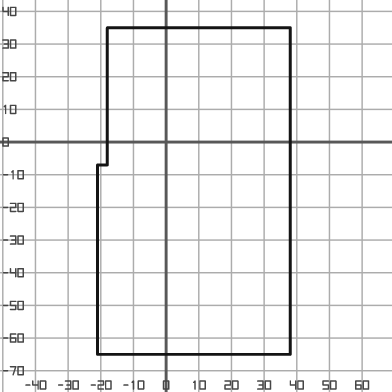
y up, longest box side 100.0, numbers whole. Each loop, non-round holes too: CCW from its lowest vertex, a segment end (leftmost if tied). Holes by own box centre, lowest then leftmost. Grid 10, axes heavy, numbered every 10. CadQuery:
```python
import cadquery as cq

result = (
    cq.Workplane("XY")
    .moveTo(-21.0, -65.0)
    .lineTo(38.0, -65.0)
    .lineTo(38.0, 35.0)
    .lineTo(-18.0, 35.0)
    .lineTo(-18.0, -7.0)
    .lineTo(-21.0, -7.0)
    .close()
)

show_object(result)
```